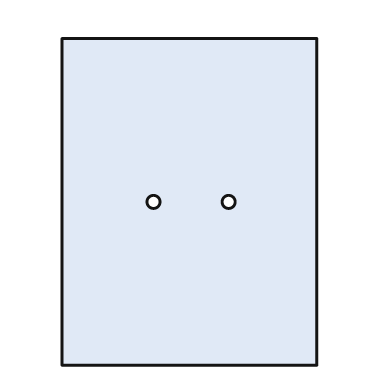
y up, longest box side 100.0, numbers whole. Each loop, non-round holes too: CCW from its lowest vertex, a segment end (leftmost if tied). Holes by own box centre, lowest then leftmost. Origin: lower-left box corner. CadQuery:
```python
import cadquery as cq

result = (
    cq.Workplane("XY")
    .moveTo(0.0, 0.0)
    .lineTo(78.0, 0.0)
    .lineTo(78.0, 100.0)
    .lineTo(0.0, 100.0)
    .close()
    .moveTo(28.0, 50.0)
    .circle(2.0)
    .moveTo(51.0, 50.0)
    .circle(2.0)
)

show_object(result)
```